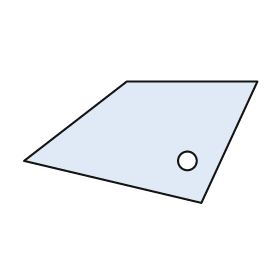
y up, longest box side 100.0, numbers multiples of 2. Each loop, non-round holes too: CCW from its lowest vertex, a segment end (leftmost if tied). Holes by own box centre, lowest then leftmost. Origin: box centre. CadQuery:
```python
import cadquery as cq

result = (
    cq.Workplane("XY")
    .moveTo(26.0, -26.0)
    .lineTo(50.0, 26.0)
    .lineTo(-6.0, 26.0)
    .lineTo(-50.0, -8.0)
    .close()
    .moveTo(20.0, -8.0)
    .circle(4.0)
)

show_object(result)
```